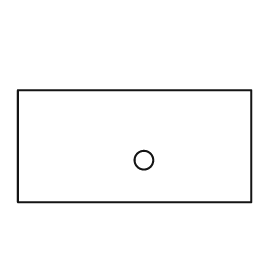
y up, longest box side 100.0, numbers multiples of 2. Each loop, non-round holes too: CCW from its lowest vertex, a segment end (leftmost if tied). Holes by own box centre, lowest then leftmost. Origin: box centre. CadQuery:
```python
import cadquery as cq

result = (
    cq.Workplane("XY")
    .moveTo(-50.0, -24.0)
    .lineTo(50.0, -24.0)
    .lineTo(50.0, 24.0)
    .lineTo(-50.0, 24.0)
    .close()
    .moveTo(4.0, -6.0)
    .circle(4.0)
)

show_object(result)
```